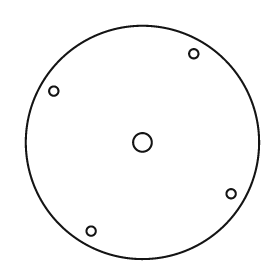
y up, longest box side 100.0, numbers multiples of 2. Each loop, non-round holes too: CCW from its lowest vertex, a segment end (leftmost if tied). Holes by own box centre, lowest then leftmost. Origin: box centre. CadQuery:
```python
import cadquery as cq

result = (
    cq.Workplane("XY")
    .moveTo(0.0, 0.0)
    .circle(50.0)
    .moveTo(-22.0, -38.0)
    .circle(2.0)
    .moveTo(38.0, -22.0)
    .circle(2.0)
    .moveTo(0.0, 0.0)
    .circle(4.0)
    .moveTo(-38.0, 22.0)
    .circle(2.0)
    .moveTo(22.0, 38.0)
    .circle(2.0)
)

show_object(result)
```